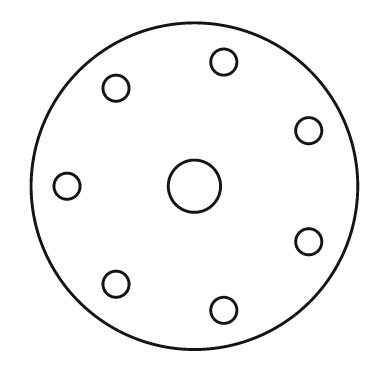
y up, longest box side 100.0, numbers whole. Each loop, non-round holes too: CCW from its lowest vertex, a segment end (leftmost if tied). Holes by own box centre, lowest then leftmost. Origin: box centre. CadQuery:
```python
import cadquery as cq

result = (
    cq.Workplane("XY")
    .moveTo(0.0, 0.0)
    .circle(50.0)
    .moveTo(9.0, -38.0)
    .circle(4.0)
    .moveTo(-24.0, -30.0)
    .circle(4.0)
    .moveTo(35.0, -17.0)
    .circle(4.0)
    .moveTo(-39.0, 0.0)
    .circle(4.0)
    .moveTo(0.0, 0.0)
    .circle(8.0)
    .moveTo(35.0, 17.0)
    .circle(4.0)
    .moveTo(-24.0, 30.0)
    .circle(4.0)
    .moveTo(9.0, 38.0)
    .circle(4.0)
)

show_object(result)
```